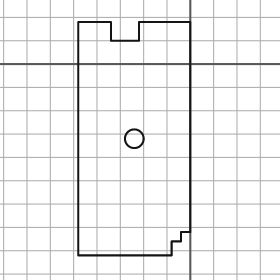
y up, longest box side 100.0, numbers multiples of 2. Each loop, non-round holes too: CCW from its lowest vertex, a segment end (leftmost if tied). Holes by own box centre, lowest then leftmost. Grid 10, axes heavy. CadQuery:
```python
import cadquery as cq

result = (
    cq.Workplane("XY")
    .moveTo(-48.0, -82.0)
    .lineTo(-8.0, -82.0)
    .lineTo(-8.0, -76.0)
    .lineTo(-4.0, -76.0)
    .lineTo(-4.0, -72.0)
    .lineTo(0.0, -72.0)
    .lineTo(0.0, 18.0)
    .lineTo(-22.0, 18.0)
    .lineTo(-22.0, 10.0)
    .lineTo(-34.0, 10.0)
    .lineTo(-34.0, 18.0)
    .lineTo(-48.0, 18.0)
    .close()
    .moveTo(-24.0, -32.0)
    .circle(4.0)
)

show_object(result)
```